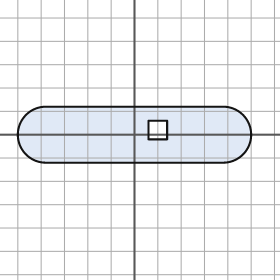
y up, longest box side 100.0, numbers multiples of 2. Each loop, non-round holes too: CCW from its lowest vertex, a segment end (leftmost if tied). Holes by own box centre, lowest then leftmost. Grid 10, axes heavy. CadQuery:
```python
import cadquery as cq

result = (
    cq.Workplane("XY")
    .moveTo(-38.0, -12.0)
    .lineTo(38.0, -12.0)
    .threePointArc((50.0, 0.0), (38.0, 12.0))
    .lineTo(-38.0, 12.0)
    .threePointArc((-50.0, 0.0), (-38.0, -12.0))
    .close()
    .moveTo(6.0, -2.0)
    .lineTo(14.0, -2.0)
    .lineTo(14.0, 6.0)
    .lineTo(6.0, 6.0)
    .close()
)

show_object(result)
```